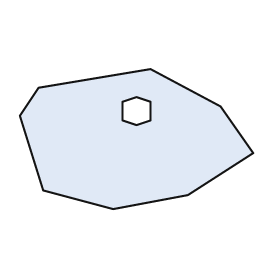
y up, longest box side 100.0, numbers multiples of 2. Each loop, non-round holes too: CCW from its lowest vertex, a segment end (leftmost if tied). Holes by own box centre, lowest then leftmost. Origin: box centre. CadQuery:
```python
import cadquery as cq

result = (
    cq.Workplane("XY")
    .moveTo(-10.0, -30.0)
    .lineTo(22.0, -24.0)
    .lineTo(50.0, -6.0)
    .lineTo(36.0, 14.0)
    .lineTo(6.0, 30.0)
    .lineTo(-42.0, 22.0)
    .lineTo(-50.0, 10.0)
    .lineTo(-40.0, -22.0)
    .close()
    .moveTo(0.0, 6.0)
    .lineTo(6.0, 8.0)
    .lineTo(6.0, 16.0)
    .lineTo(0.0, 18.0)
    .lineTo(-6.0, 16.0)
    .lineTo(-6.0, 8.0)
    .close()
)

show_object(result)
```